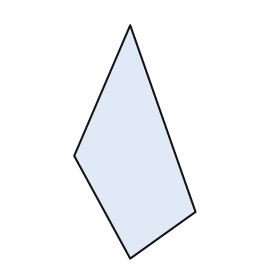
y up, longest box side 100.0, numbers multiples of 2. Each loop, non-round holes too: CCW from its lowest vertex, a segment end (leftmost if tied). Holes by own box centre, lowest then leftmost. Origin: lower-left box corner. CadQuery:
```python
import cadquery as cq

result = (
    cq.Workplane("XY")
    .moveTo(24.0, 0.0)
    .lineTo(52.0, 20.0)
    .lineTo(24.0, 100.0)
    .lineTo(0.0, 44.0)
    .close()
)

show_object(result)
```